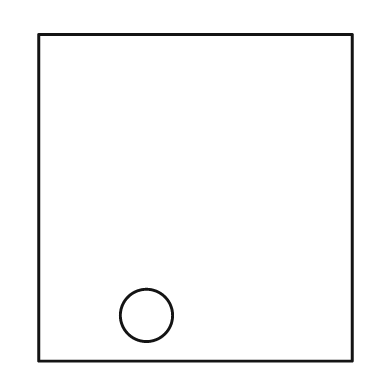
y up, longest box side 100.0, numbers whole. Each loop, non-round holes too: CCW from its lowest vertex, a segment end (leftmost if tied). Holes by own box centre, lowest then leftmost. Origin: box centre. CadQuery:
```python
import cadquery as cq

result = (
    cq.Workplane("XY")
    .moveTo(-48.0, -50.0)
    .lineTo(48.0, -50.0)
    .lineTo(48.0, 50.0)
    .lineTo(-48.0, 50.0)
    .close()
    .moveTo(-15.0, -36.0)
    .circle(8.0)
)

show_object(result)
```